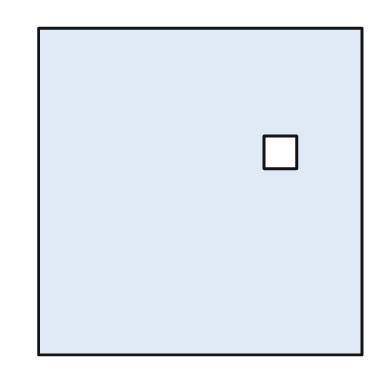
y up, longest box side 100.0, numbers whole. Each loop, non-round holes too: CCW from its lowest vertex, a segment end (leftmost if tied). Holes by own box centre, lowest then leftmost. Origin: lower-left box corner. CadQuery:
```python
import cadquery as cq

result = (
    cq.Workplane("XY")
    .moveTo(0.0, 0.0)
    .lineTo(99.0, 0.0)
    .lineTo(99.0, 100.0)
    .lineTo(0.0, 100.0)
    .close()
    .moveTo(69.0, 57.0)
    .lineTo(79.0, 57.0)
    .lineTo(79.0, 67.0)
    .lineTo(69.0, 67.0)
    .close()
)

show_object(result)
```